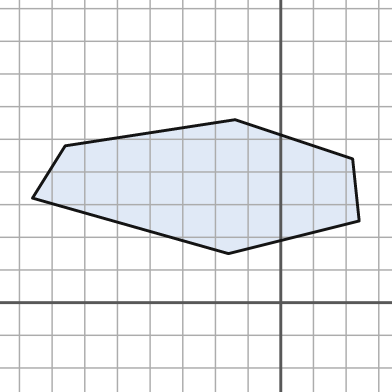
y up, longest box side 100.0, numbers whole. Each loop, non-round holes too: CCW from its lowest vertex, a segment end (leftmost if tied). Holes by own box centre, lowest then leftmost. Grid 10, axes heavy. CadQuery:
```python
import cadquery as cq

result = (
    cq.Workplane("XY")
    .moveTo(-16.0, 15.0)
    .lineTo(24.0, 25.0)
    .lineTo(22.0, 44.0)
    .lineTo(-14.0, 56.0)
    .lineTo(-66.0, 48.0)
    .lineTo(-76.0, 32.0)
    .close()
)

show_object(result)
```